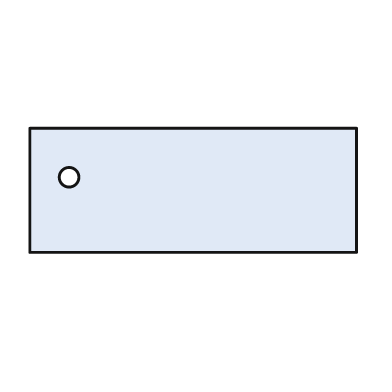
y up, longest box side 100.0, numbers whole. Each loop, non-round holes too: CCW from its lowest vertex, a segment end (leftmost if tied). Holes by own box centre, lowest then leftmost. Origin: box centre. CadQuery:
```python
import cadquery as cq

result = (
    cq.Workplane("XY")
    .moveTo(-50.0, -19.0)
    .lineTo(50.0, -19.0)
    .lineTo(50.0, 19.0)
    .lineTo(-50.0, 19.0)
    .close()
    .moveTo(-38.0, 4.0)
    .circle(3.0)
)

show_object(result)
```